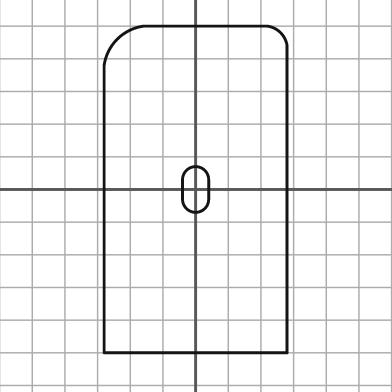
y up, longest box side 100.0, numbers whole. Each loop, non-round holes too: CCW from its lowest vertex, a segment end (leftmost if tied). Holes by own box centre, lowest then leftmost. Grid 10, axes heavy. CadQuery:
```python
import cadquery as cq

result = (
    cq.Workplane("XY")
    .moveTo(-28.0, -50.0)
    .lineTo(28.0, -50.0)
    .lineTo(28.0, 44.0)
    .threePointArc((26.0, 48.0), (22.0, 50.0))
    .lineTo(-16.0, 50.0)
    .threePointArc((-24.0, 46.0), (-28.0, 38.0))
    .close()
    .moveTo(-4.0, -3.0)
    .threePointArc((0.0, -7.0), (4.0, -3.0))
    .lineTo(4.0, 3.0)
    .threePointArc((0.0, 7.0), (-4.0, 3.0))
    .close()
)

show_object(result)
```